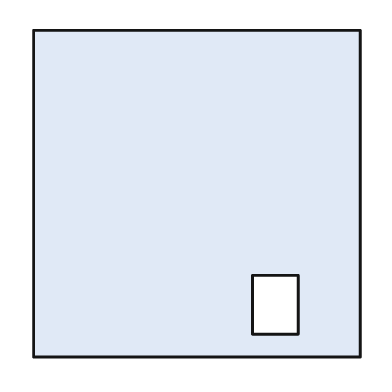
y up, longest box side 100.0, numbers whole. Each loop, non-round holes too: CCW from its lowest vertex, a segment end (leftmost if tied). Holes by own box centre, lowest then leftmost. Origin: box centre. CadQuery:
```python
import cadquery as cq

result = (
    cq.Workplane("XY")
    .moveTo(-50.0, -50.0)
    .lineTo(50.0, -50.0)
    .lineTo(50.0, 50.0)
    .lineTo(-50.0, 50.0)
    .close()
    .moveTo(17.0, -43.0)
    .lineTo(31.0, -43.0)
    .lineTo(31.0, -25.0)
    .lineTo(17.0, -25.0)
    .close()
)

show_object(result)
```